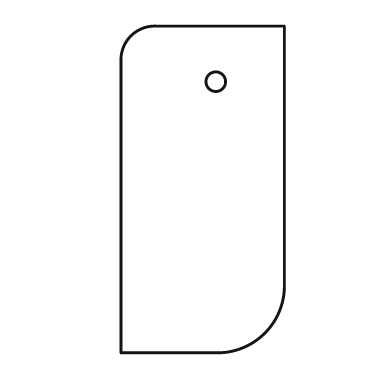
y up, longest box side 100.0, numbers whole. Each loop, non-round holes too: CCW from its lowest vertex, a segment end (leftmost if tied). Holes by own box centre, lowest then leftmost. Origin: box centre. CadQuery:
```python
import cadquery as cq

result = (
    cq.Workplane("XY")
    .moveTo(-25.0, -50.0)
    .lineTo(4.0, -50.0)
    .threePointArc((19.0, -44.0), (25.0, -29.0))
    .lineTo(25.0, 50.0)
    .lineTo(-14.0, 50.0)
    .threePointArc((-22.0, 47.0), (-25.0, 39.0))
    .close()
    .moveTo(4.0, 33.0)
    .circle(3.0)
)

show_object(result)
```